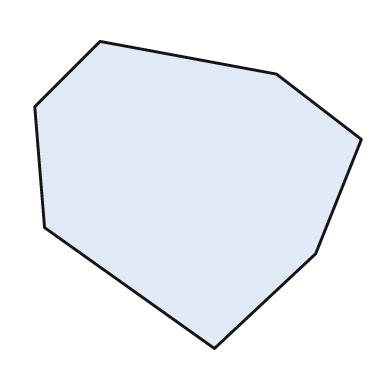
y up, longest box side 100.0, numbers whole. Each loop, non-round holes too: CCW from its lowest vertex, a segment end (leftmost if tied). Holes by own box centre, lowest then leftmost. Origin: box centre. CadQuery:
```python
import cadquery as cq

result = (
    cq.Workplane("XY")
    .moveTo(5.0, -47.0)
    .lineTo(36.0, -18.0)
    .lineTo(50.0, 17.0)
    .lineTo(24.0, 37.0)
    .lineTo(-30.0, 47.0)
    .lineTo(-50.0, 27.0)
    .lineTo(-47.0, -10.0)
    .close()
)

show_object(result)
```